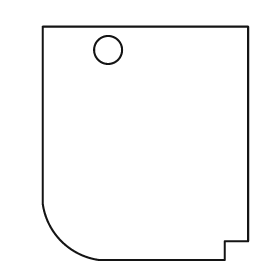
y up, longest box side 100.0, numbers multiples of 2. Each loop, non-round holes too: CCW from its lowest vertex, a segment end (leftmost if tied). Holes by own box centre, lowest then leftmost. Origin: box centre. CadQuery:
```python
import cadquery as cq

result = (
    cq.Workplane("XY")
    .moveTo(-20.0, -50.0)
    .lineTo(34.0, -50.0)
    .lineTo(34.0, -42.0)
    .lineTo(44.0, -42.0)
    .lineTo(44.0, 50.0)
    .lineTo(-44.0, 50.0)
    .lineTo(-44.0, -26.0)
    .threePointArc((-36.0, -42.0), (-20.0, -50.0))
    .close()
    .moveTo(-16.0, 40.0)
    .circle(6.0)
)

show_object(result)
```